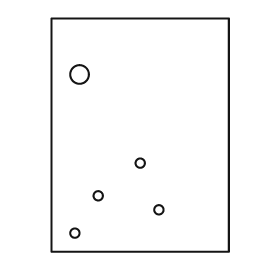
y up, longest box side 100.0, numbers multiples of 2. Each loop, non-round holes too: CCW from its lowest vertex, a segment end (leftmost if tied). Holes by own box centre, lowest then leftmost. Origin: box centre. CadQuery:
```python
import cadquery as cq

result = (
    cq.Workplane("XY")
    .moveTo(-38.0, -50.0)
    .lineTo(38.0, -50.0)
    .lineTo(38.0, 50.0)
    .lineTo(-38.0, 50.0)
    .close()
    .moveTo(-28.0, -42.0)
    .circle(2.0)
    .moveTo(8.0, -32.0)
    .circle(2.0)
    .moveTo(-18.0, -26.0)
    .circle(2.0)
    .moveTo(0.0, -12.0)
    .circle(2.0)
    .moveTo(-26.0, 26.0)
    .circle(4.0)
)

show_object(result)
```